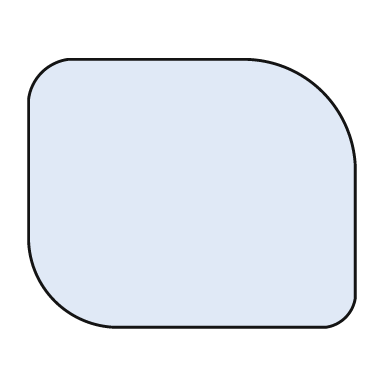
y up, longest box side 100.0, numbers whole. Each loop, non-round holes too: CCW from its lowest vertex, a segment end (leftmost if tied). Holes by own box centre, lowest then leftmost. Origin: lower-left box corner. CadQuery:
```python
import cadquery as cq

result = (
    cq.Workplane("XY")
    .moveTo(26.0, 0.0)
    .lineTo(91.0, 0.0)
    .threePointArc((97.0, 3.0), (100.0, 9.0))
    .lineTo(100.0, 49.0)
    .threePointArc((90.0, 72.0), (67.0, 82.0))
    .lineTo(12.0, 82.0)
    .threePointArc((4.0, 78.0), (0.0, 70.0))
    .lineTo(0.0, 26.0)
    .threePointArc((8.0, 8.0), (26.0, 0.0))
    .close()
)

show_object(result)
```